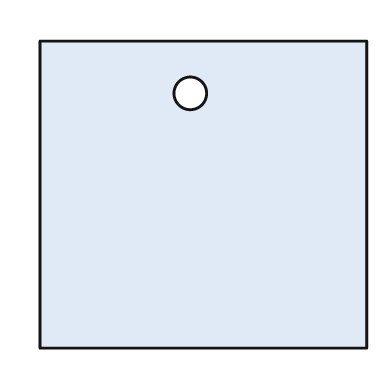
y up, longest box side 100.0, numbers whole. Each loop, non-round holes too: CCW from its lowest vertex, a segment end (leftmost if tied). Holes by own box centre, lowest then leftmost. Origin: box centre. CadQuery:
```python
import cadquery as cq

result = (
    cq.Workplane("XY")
    .moveTo(-50.0, -47.0)
    .lineTo(50.0, -47.0)
    .lineTo(50.0, 47.0)
    .lineTo(-50.0, 47.0)
    .close()
    .moveTo(-4.0, 31.0)
    .circle(5.0)
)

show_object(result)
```